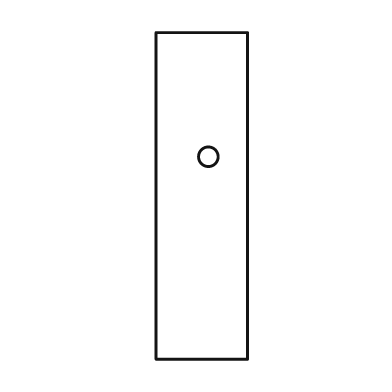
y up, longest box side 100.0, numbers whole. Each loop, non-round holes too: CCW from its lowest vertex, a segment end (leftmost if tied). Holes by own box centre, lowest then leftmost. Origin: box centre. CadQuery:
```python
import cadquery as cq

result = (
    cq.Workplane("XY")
    .moveTo(-14.0, -50.0)
    .lineTo(14.0, -50.0)
    .lineTo(14.0, 50.0)
    .lineTo(-14.0, 50.0)
    .close()
    .moveTo(2.0, 12.0)
    .circle(3.0)
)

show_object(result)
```